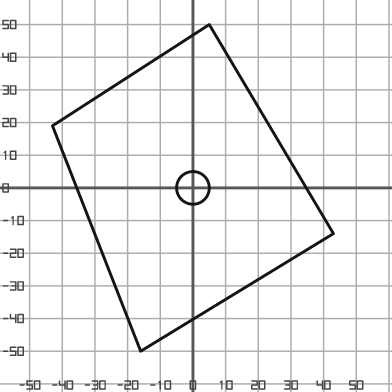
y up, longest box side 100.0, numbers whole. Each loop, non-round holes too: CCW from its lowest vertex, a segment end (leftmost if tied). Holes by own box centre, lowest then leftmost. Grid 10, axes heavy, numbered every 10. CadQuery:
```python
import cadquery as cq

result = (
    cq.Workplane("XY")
    .moveTo(-16.0, -50.0)
    .lineTo(43.0, -14.0)
    .lineTo(5.0, 50.0)
    .lineTo(-43.0, 19.0)
    .close()
    .moveTo(0.0, 0.0)
    .circle(5.0)
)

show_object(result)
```